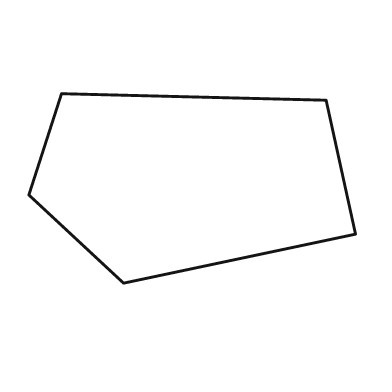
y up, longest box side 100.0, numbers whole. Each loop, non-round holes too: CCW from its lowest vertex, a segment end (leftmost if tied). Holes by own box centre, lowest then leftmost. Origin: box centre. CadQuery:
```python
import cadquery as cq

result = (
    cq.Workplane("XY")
    .moveTo(-21.0, -29.0)
    .lineTo(50.0, -14.0)
    .lineTo(41.0, 27.0)
    .lineTo(-40.0, 29.0)
    .lineTo(-50.0, -2.0)
    .close()
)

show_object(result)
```